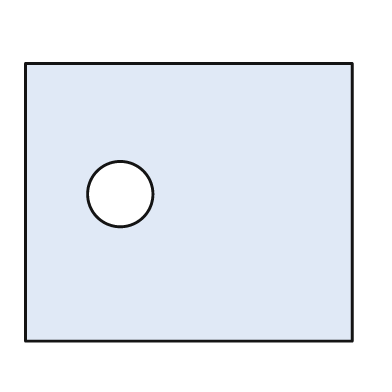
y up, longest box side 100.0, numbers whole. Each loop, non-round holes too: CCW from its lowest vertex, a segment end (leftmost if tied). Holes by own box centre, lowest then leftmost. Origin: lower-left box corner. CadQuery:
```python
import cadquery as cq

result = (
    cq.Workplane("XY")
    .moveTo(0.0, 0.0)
    .lineTo(100.0, 0.0)
    .lineTo(100.0, 85.0)
    .lineTo(0.0, 85.0)
    .close()
    .moveTo(29.0, 45.0)
    .circle(10.0)
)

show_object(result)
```